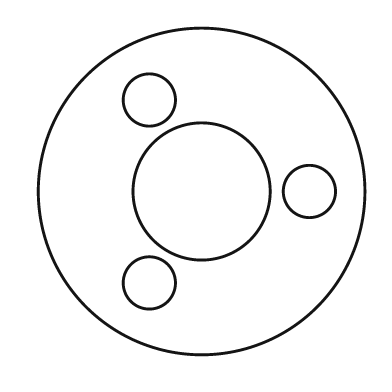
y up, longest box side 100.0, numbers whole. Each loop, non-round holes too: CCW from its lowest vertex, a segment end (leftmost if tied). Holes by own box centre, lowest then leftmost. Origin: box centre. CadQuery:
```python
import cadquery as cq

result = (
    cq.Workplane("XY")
    .moveTo(0.0, 0.0)
    .circle(50.0)
    .moveTo(-16.0, -28.0)
    .circle(8.0)
    .moveTo(0.0, 0.0)
    .circle(21.0)
    .moveTo(33.0, 0.0)
    .circle(8.0)
    .moveTo(-16.0, 28.0)
    .circle(8.0)
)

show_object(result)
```